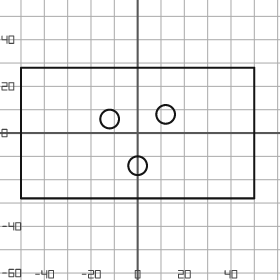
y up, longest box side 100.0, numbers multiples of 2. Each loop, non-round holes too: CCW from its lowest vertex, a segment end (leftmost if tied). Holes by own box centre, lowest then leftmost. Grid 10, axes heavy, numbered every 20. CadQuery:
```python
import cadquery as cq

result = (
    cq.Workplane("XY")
    .moveTo(-50.0, -28.0)
    .lineTo(50.0, -28.0)
    .lineTo(50.0, 28.0)
    .lineTo(-50.0, 28.0)
    .close()
    .moveTo(0.0, -14.0)
    .circle(4.0)
    .moveTo(-12.0, 6.0)
    .circle(4.0)
    .moveTo(12.0, 8.0)
    .circle(4.0)
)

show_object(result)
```